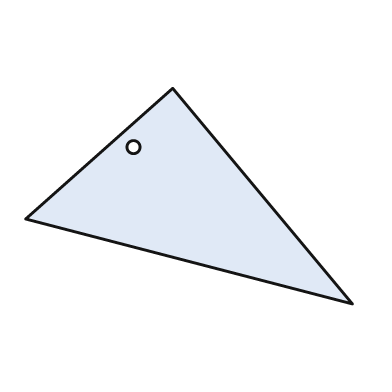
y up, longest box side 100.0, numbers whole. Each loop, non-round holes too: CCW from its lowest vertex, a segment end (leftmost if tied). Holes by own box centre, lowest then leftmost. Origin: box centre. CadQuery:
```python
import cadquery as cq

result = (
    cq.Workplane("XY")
    .moveTo(50.0, -33.0)
    .lineTo(-5.0, 33.0)
    .lineTo(-50.0, -7.0)
    .close()
    .moveTo(-17.0, 15.0)
    .circle(2.0)
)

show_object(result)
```